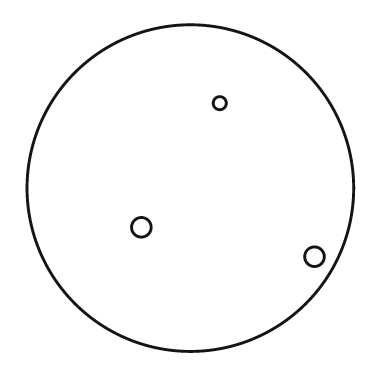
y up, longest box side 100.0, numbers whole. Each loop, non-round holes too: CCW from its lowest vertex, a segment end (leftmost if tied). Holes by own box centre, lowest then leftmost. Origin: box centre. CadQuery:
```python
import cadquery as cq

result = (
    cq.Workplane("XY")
    .moveTo(0.0, 0.0)
    .circle(50.0)
    .moveTo(38.0, -21.0)
    .circle(3.0)
    .moveTo(-15.0, -12.0)
    .circle(3.0)
    .moveTo(9.0, 26.0)
    .circle(2.0)
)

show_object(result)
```